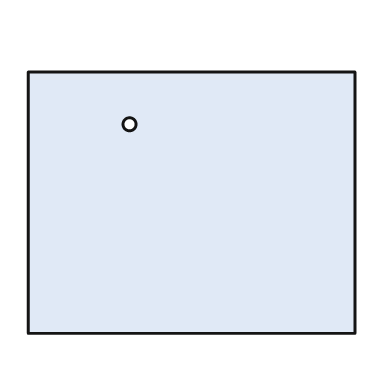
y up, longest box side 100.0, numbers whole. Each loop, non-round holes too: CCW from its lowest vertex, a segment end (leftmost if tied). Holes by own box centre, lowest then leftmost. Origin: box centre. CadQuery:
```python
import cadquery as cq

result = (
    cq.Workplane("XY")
    .moveTo(-50.0, -40.0)
    .lineTo(50.0, -40.0)
    .lineTo(50.0, 40.0)
    .lineTo(-50.0, 40.0)
    .close()
    .moveTo(-19.0, 24.0)
    .circle(2.0)
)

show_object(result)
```